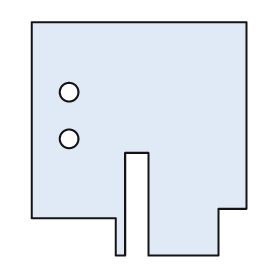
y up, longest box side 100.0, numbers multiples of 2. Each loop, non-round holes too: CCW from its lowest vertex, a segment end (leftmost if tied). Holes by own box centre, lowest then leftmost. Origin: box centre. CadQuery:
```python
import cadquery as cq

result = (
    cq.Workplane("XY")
    .moveTo(-10.0, -50.0)
    .lineTo(-6.0, -50.0)
    .lineTo(-6.0, -6.0)
    .lineTo(4.0, -6.0)
    .lineTo(4.0, -50.0)
    .lineTo(34.0, -50.0)
    .lineTo(34.0, -30.0)
    .lineTo(46.0, -30.0)
    .lineTo(46.0, 50.0)
    .lineTo(-46.0, 50.0)
    .lineTo(-46.0, -34.0)
    .lineTo(-10.0, -34.0)
    .close()
    .moveTo(-30.0, 0.0)
    .circle(4.0)
    .moveTo(-30.0, 20.0)
    .circle(4.0)
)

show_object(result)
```